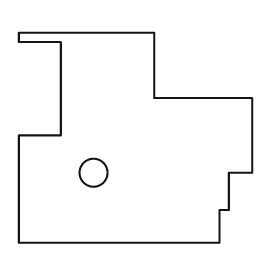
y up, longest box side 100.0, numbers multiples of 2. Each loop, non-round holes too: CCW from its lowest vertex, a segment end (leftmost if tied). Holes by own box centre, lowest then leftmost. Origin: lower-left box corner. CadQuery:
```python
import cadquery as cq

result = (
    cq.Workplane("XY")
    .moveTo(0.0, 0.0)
    .lineTo(86.0, 0.0)
    .lineTo(86.0, 14.0)
    .lineTo(90.0, 14.0)
    .lineTo(90.0, 30.0)
    .lineTo(100.0, 30.0)
    .lineTo(100.0, 62.0)
    .lineTo(58.0, 62.0)
    .lineTo(58.0, 90.0)
    .lineTo(0.0, 90.0)
    .lineTo(0.0, 86.0)
    .lineTo(18.0, 86.0)
    .lineTo(18.0, 46.0)
    .lineTo(0.0, 46.0)
    .close()
    .moveTo(32.0, 30.0)
    .circle(6.0)
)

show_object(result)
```